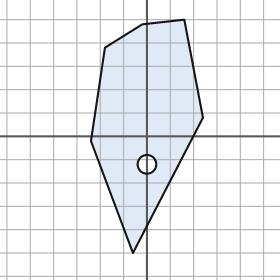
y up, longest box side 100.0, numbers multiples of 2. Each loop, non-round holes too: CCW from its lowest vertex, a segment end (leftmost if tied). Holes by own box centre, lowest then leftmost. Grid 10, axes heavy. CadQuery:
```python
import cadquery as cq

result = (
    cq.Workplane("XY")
    .moveTo(-6.0, -50.0)
    .lineTo(24.0, 8.0)
    .lineTo(16.0, 50.0)
    .lineTo(-2.0, 48.0)
    .lineTo(-18.0, 38.0)
    .lineTo(-24.0, -2.0)
    .close()
    .moveTo(0.0, -12.0)
    .circle(4.0)
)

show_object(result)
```